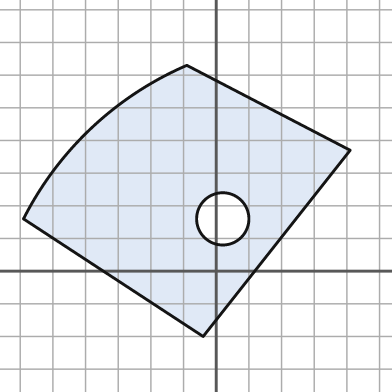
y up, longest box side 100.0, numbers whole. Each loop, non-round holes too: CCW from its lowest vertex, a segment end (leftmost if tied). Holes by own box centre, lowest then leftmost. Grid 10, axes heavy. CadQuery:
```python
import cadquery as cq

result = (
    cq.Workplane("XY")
    .moveTo(-4.0, -20.0)
    .lineTo(41.0, 37.0)
    .lineTo(-9.0, 63.0)
    .threePointArc((-38.0, 44.0), (-59.0, 16.0))
    .close()
    .moveTo(2.0, 16.0)
    .circle(8.0)
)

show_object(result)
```